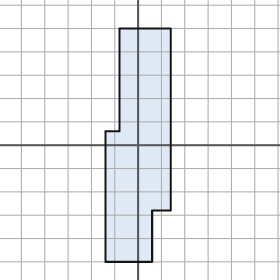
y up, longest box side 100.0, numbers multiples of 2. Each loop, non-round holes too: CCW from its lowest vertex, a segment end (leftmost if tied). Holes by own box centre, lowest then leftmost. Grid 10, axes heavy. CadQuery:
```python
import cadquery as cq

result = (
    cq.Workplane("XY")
    .moveTo(-14.0, -50.0)
    .lineTo(6.0, -50.0)
    .lineTo(6.0, -28.0)
    .lineTo(14.0, -28.0)
    .lineTo(14.0, 50.0)
    .lineTo(-8.0, 50.0)
    .lineTo(-8.0, 6.0)
    .lineTo(-14.0, 6.0)
    .close()
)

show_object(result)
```